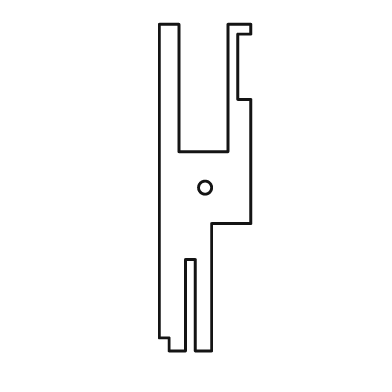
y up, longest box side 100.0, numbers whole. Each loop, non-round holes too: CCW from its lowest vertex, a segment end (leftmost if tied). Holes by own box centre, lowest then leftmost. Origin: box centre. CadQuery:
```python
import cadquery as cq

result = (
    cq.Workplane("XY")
    .moveTo(-11.0, -50.0)
    .lineTo(-6.0, -50.0)
    .lineTo(-6.0, -22.0)
    .lineTo(-3.0, -22.0)
    .lineTo(-3.0, -50.0)
    .lineTo(2.0, -50.0)
    .lineTo(2.0, -11.0)
    .lineTo(14.0, -11.0)
    .lineTo(14.0, 27.0)
    .lineTo(10.0, 27.0)
    .lineTo(10.0, 47.0)
    .lineTo(14.0, 47.0)
    .lineTo(14.0, 50.0)
    .lineTo(7.0, 50.0)
    .lineTo(7.0, 11.0)
    .lineTo(-8.0, 11.0)
    .lineTo(-8.0, 50.0)
    .lineTo(-14.0, 50.0)
    .lineTo(-14.0, -46.0)
    .lineTo(-11.0, -46.0)
    .close()
    .moveTo(0.0, 0.0)
    .circle(2.0)
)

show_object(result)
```